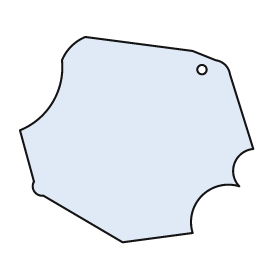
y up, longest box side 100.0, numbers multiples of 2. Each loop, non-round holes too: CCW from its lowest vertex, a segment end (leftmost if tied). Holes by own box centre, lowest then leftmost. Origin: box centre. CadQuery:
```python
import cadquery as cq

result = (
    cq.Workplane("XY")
    .moveTo(-6.0, -44.0)
    .lineTo(24.0, -40.0)
    .threePointArc((28.0, -24.0), (44.0, -20.0))
    .threePointArc((42.0, -10.0), (50.0, -4.0))
    .lineTo(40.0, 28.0)
    .threePointArc((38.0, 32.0), (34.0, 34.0))
    .lineTo(24.0, 38.0)
    .lineTo(-22.0, 44.0)
    .threePointArc((-28.0, 40.0), (-32.0, 34.0))
    .threePointArc((-36.0, 16.0), (-50.0, 4.0))
    .lineTo(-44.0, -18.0)
    .threePointArc((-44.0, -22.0), (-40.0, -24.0))
    .close()
    .moveTo(28.0, 30.0)
    .circle(2.0)
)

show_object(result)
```